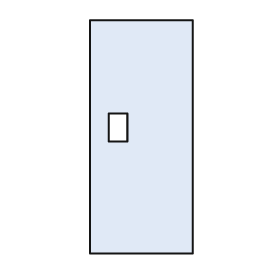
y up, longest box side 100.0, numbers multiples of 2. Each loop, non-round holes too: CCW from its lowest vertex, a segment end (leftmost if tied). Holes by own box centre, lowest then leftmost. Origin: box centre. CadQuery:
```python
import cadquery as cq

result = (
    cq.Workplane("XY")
    .moveTo(-22.0, -50.0)
    .lineTo(22.0, -50.0)
    .lineTo(22.0, 50.0)
    .lineTo(-22.0, 50.0)
    .close()
    .moveTo(-14.0, -2.0)
    .lineTo(-6.0, -2.0)
    .lineTo(-6.0, 10.0)
    .lineTo(-14.0, 10.0)
    .close()
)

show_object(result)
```